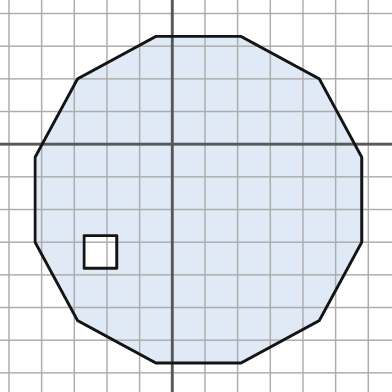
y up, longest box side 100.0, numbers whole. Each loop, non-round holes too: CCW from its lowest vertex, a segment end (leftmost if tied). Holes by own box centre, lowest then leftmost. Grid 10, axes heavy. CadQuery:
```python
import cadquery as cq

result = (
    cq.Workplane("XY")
    .moveTo(-5.0, -67.0)
    .lineTo(21.0, -67.0)
    .lineTo(45.0, -54.0)
    .lineTo(58.0, -30.0)
    .lineTo(58.0, -4.0)
    .lineTo(45.0, 20.0)
    .lineTo(21.0, 33.0)
    .lineTo(-5.0, 33.0)
    .lineTo(-29.0, 20.0)
    .lineTo(-42.0, -4.0)
    .lineTo(-42.0, -30.0)
    .lineTo(-29.0, -54.0)
    .close()
    .moveTo(-27.0, -38.0)
    .lineTo(-17.0, -38.0)
    .lineTo(-17.0, -28.0)
    .lineTo(-27.0, -28.0)
    .close()
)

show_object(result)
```